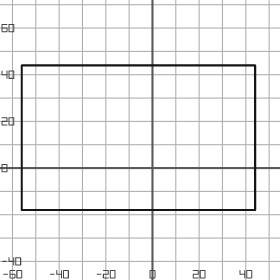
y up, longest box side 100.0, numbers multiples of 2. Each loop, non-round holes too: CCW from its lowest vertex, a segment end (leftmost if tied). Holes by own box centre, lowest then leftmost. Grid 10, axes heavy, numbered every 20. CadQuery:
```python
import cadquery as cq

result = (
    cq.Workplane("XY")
    .moveTo(-56.0, -18.0)
    .lineTo(44.0, -18.0)
    .lineTo(44.0, 44.0)
    .lineTo(-56.0, 44.0)
    .close()
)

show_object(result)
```